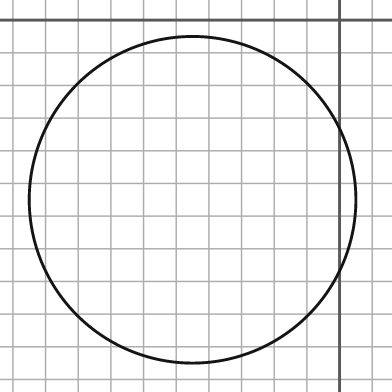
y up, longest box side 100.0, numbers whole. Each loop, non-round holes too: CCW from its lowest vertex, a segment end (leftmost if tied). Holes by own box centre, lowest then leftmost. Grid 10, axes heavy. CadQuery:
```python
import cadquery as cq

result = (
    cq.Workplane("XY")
    .moveTo(-45.0, -55.0)
    .circle(50.0)
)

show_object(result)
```